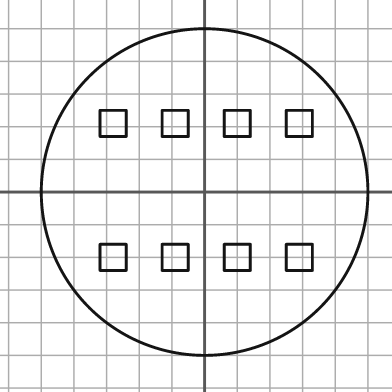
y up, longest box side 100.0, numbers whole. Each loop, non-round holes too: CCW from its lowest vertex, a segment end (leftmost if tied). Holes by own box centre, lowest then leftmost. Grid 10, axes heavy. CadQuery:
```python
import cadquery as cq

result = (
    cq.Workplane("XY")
    .moveTo(0.0, 0.0)
    .circle(50.0)
    .moveTo(-32.0, -24.0)
    .lineTo(-24.0, -24.0)
    .lineTo(-24.0, -16.0)
    .lineTo(-32.0, -16.0)
    .close()
    .moveTo(-13.0, -24.0)
    .lineTo(-5.0, -24.0)
    .lineTo(-5.0, -16.0)
    .lineTo(-13.0, -16.0)
    .close()
    .moveTo(6.0, -24.0)
    .lineTo(14.0, -24.0)
    .lineTo(14.0, -16.0)
    .lineTo(6.0, -16.0)
    .close()
    .moveTo(25.0, -24.0)
    .lineTo(33.0, -24.0)
    .lineTo(33.0, -16.0)
    .lineTo(25.0, -16.0)
    .close()
    .moveTo(-32.0, 17.0)
    .lineTo(-24.0, 17.0)
    .lineTo(-24.0, 25.0)
    .lineTo(-32.0, 25.0)
    .close()
    .moveTo(-13.0, 17.0)
    .lineTo(-5.0, 17.0)
    .lineTo(-5.0, 25.0)
    .lineTo(-13.0, 25.0)
    .close()
    .moveTo(6.0, 17.0)
    .lineTo(14.0, 17.0)
    .lineTo(14.0, 25.0)
    .lineTo(6.0, 25.0)
    .close()
    .moveTo(25.0, 17.0)
    .lineTo(33.0, 17.0)
    .lineTo(33.0, 25.0)
    .lineTo(25.0, 25.0)
    .close()
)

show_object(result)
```